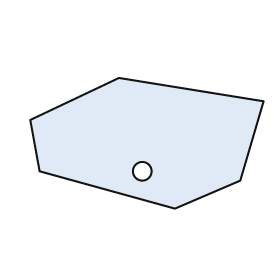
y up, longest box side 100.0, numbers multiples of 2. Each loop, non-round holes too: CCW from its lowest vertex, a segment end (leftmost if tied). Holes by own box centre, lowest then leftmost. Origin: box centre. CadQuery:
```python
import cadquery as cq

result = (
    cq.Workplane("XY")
    .moveTo(12.0, -28.0)
    .lineTo(40.0, -16.0)
    .lineTo(50.0, 18.0)
    .lineTo(-12.0, 28.0)
    .lineTo(-50.0, 10.0)
    .lineTo(-46.0, -12.0)
    .close()
    .moveTo(-2.0, -12.0)
    .circle(4.0)
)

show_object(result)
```